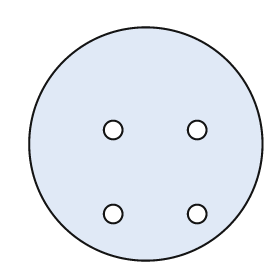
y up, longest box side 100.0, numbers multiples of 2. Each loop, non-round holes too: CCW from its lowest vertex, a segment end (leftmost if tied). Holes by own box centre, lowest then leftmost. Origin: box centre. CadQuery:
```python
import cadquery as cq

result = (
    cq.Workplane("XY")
    .moveTo(0.0, 0.0)
    .circle(50.0)
    .moveTo(-14.0, -30.0)
    .circle(4.0)
    .moveTo(22.0, -30.0)
    .circle(4.0)
    .moveTo(-14.0, 6.0)
    .circle(4.0)
    .moveTo(22.0, 6.0)
    .circle(4.0)
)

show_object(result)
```